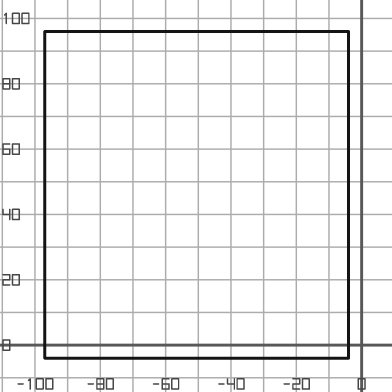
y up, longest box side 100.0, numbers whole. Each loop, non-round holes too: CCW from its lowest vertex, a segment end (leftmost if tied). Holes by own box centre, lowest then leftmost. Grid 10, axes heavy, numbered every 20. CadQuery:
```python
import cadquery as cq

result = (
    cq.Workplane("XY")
    .moveTo(-97.0, -4.0)
    .lineTo(-4.0, -4.0)
    .lineTo(-4.0, 96.0)
    .lineTo(-97.0, 96.0)
    .close()
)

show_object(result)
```